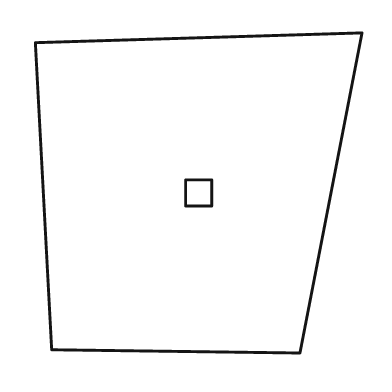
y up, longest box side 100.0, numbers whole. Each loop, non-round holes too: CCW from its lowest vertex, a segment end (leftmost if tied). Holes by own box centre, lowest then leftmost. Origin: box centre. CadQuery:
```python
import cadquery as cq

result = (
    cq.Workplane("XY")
    .moveTo(31.0, -49.0)
    .lineTo(50.0, 49.0)
    .lineTo(-50.0, 46.0)
    .lineTo(-45.0, -48.0)
    .close()
    .moveTo(-4.0, -4.0)
    .lineTo(4.0, -4.0)
    .lineTo(4.0, 4.0)
    .lineTo(-4.0, 4.0)
    .close()
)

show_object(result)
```